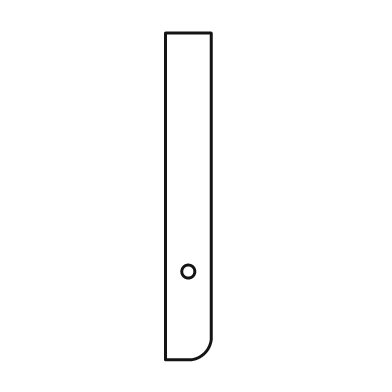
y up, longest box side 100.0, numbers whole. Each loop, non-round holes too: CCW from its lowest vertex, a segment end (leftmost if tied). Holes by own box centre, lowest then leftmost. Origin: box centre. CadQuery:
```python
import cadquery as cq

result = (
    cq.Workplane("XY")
    .moveTo(-7.0, -50.0)
    .lineTo(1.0, -50.0)
    .threePointArc((5.0, -48.0), (7.0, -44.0))
    .lineTo(7.0, 50.0)
    .lineTo(-7.0, 50.0)
    .close()
    .moveTo(0.0, -23.0)
    .circle(2.0)
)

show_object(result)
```